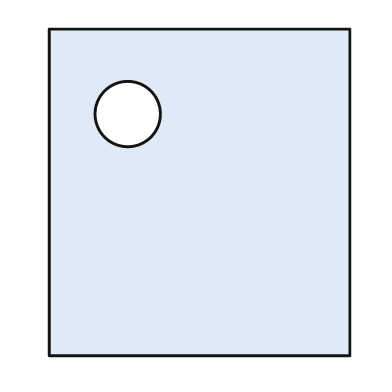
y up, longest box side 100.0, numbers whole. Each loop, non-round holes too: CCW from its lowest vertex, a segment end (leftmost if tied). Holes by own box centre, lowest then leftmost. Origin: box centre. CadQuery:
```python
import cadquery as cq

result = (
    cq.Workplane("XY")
    .moveTo(-46.0, -50.0)
    .lineTo(46.0, -50.0)
    .lineTo(46.0, 50.0)
    .lineTo(-46.0, 50.0)
    .close()
    .moveTo(-22.0, 24.0)
    .circle(10.0)
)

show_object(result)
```